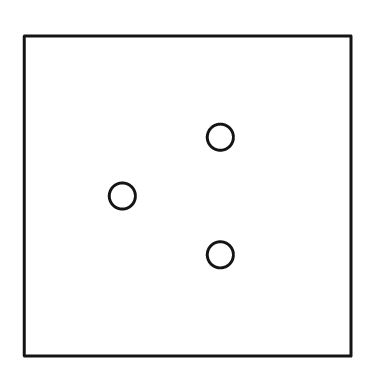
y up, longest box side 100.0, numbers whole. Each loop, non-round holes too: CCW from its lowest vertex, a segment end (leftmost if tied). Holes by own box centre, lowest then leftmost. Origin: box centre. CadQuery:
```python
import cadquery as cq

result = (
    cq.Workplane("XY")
    .moveTo(-50.0, -49.0)
    .lineTo(50.0, -49.0)
    .lineTo(50.0, 49.0)
    .lineTo(-50.0, 49.0)
    .close()
    .moveTo(10.0, -18.0)
    .circle(4.0)
    .moveTo(-20.0, 0.0)
    .circle(4.0)
    .moveTo(10.0, 18.0)
    .circle(4.0)
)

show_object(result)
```